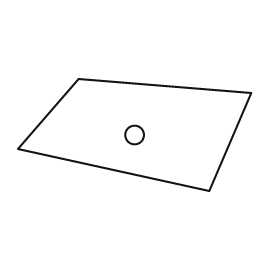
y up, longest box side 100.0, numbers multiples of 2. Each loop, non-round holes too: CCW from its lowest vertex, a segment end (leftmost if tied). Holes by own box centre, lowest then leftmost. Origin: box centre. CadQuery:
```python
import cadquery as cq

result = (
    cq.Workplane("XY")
    .moveTo(32.0, -24.0)
    .lineTo(50.0, 18.0)
    .lineTo(-24.0, 24.0)
    .lineTo(-50.0, -6.0)
    .close()
    .moveTo(0.0, 0.0)
    .circle(4.0)
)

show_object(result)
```